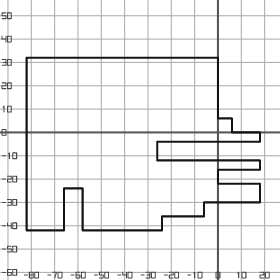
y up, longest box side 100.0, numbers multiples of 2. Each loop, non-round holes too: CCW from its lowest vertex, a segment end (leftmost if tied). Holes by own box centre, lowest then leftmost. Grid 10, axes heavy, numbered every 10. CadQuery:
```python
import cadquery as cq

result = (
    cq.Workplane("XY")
    .moveTo(-82.0, -42.0)
    .lineTo(-66.0, -42.0)
    .lineTo(-66.0, -24.0)
    .lineTo(-58.0, -24.0)
    .lineTo(-58.0, -42.0)
    .lineTo(-24.0, -42.0)
    .lineTo(-24.0, -36.0)
    .lineTo(-6.0, -36.0)
    .lineTo(-6.0, -30.0)
    .lineTo(18.0, -30.0)
    .lineTo(18.0, -22.0)
    .lineTo(0.0, -22.0)
    .lineTo(0.0, -16.0)
    .lineTo(18.0, -16.0)
    .lineTo(18.0, -12.0)
    .lineTo(-26.0, -12.0)
    .lineTo(-26.0, -4.0)
    .lineTo(18.0, -4.0)
    .lineTo(18.0, 0.0)
    .lineTo(6.0, 0.0)
    .lineTo(6.0, 6.0)
    .lineTo(0.0, 6.0)
    .lineTo(0.0, 32.0)
    .lineTo(-82.0, 32.0)
    .close()
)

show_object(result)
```